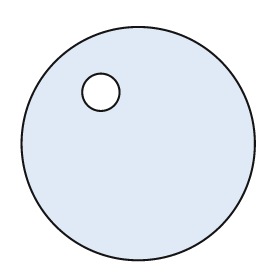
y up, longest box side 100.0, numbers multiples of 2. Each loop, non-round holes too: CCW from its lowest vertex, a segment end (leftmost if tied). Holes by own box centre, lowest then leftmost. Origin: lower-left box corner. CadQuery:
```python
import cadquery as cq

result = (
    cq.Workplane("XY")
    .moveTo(50.0, 50.0)
    .circle(50.0)
    .moveTo(34.0, 72.0)
    .circle(8.0)
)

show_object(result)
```